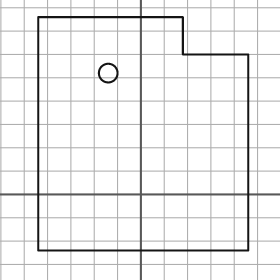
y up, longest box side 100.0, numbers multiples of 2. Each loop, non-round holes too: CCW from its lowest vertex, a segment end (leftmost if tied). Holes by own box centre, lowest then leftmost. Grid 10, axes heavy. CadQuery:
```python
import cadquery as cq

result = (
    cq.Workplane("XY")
    .moveTo(-44.0, -24.0)
    .lineTo(46.0, -24.0)
    .lineTo(46.0, 60.0)
    .lineTo(18.0, 60.0)
    .lineTo(18.0, 76.0)
    .lineTo(-44.0, 76.0)
    .close()
    .moveTo(-14.0, 52.0)
    .circle(4.0)
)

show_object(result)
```